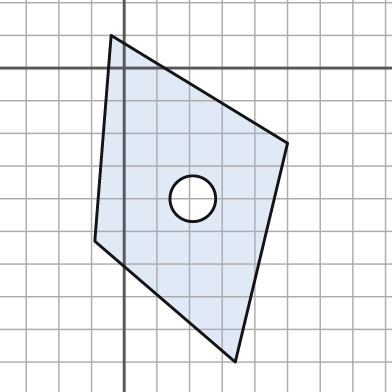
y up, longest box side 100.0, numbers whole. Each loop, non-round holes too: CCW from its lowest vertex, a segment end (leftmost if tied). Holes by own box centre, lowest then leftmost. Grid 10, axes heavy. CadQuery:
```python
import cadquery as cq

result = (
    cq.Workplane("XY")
    .moveTo(34.0, -90.0)
    .lineTo(50.0, -23.0)
    .lineTo(-4.0, 10.0)
    .lineTo(-9.0, -53.0)
    .close()
    .moveTo(21.0, -40.0)
    .circle(7.0)
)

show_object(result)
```